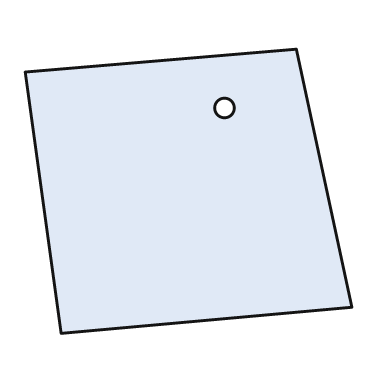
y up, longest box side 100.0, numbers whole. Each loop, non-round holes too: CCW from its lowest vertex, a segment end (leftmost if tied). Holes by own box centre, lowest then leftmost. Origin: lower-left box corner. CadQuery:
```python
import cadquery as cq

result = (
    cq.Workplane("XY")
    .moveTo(11.0, 0.0)
    .lineTo(100.0, 8.0)
    .lineTo(83.0, 87.0)
    .lineTo(0.0, 80.0)
    .close()
    .moveTo(61.0, 69.0)
    .circle(3.0)
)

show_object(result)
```